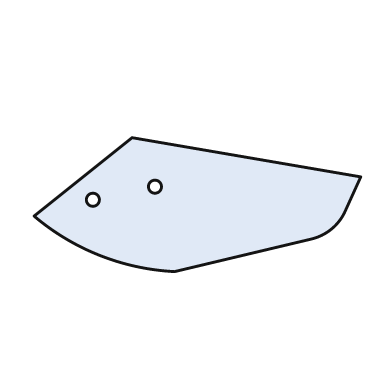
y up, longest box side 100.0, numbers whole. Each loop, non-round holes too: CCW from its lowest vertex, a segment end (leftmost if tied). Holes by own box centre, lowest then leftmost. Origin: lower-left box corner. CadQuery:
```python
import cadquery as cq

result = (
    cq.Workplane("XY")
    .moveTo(43.0, 0.0)
    .lineTo(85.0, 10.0)
    .threePointArc((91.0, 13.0), (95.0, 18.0))
    .lineTo(100.0, 29.0)
    .lineTo(30.0, 41.0)
    .lineTo(0.0, 17.0)
    .threePointArc((20.0, 5.0), (43.0, 0.0))
    .close()
    .moveTo(18.0, 22.0)
    .circle(2.0)
    .moveTo(37.0, 26.0)
    .circle(2.0)
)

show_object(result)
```